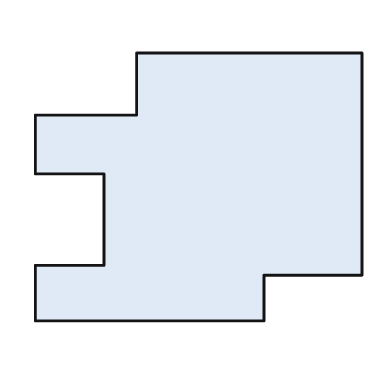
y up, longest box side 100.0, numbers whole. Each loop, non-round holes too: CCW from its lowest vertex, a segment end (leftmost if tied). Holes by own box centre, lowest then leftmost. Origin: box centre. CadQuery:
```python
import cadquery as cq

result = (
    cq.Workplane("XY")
    .moveTo(-50.0, -41.0)
    .lineTo(20.0, -41.0)
    .lineTo(20.0, -27.0)
    .lineTo(50.0, -27.0)
    .lineTo(50.0, 41.0)
    .lineTo(-19.0, 41.0)
    .lineTo(-19.0, 22.0)
    .lineTo(-50.0, 22.0)
    .lineTo(-50.0, 4.0)
    .lineTo(-29.0, 4.0)
    .lineTo(-29.0, -24.0)
    .lineTo(-50.0, -24.0)
    .close()
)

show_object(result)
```